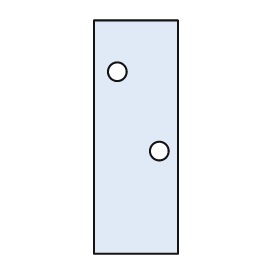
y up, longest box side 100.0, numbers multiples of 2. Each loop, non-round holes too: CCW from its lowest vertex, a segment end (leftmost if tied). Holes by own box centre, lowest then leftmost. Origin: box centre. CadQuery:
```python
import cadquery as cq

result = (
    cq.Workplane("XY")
    .moveTo(-18.0, -50.0)
    .lineTo(18.0, -50.0)
    .lineTo(18.0, 50.0)
    .lineTo(-18.0, 50.0)
    .close()
    .moveTo(10.0, -6.0)
    .circle(4.0)
    .moveTo(-8.0, 28.0)
    .circle(4.0)
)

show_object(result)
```